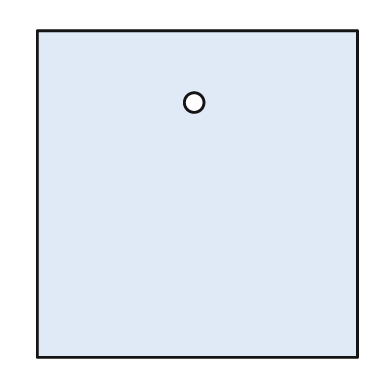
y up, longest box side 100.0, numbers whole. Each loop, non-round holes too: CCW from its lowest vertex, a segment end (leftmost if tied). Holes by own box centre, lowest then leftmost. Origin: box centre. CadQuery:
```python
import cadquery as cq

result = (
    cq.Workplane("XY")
    .moveTo(-49.0, -50.0)
    .lineTo(49.0, -50.0)
    .lineTo(49.0, 50.0)
    .lineTo(-49.0, 50.0)
    .close()
    .moveTo(-1.0, 28.0)
    .circle(3.0)
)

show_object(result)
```